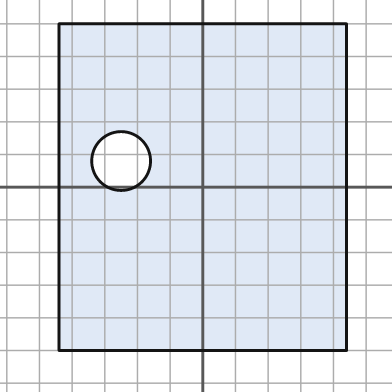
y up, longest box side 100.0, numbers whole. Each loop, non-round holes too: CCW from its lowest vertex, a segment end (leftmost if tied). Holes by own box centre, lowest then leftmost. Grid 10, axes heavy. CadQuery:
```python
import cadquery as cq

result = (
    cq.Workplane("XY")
    .moveTo(-44.0, -50.0)
    .lineTo(44.0, -50.0)
    .lineTo(44.0, 50.0)
    .lineTo(-44.0, 50.0)
    .close()
    .moveTo(-25.0, 8.0)
    .circle(9.0)
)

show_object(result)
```